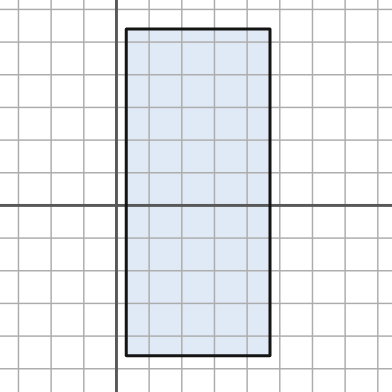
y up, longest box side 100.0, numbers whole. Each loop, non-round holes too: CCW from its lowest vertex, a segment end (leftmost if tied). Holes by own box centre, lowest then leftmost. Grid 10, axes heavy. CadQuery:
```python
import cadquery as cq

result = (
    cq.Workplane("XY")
    .moveTo(3.0, -46.0)
    .lineTo(47.0, -46.0)
    .lineTo(47.0, 54.0)
    .lineTo(3.0, 54.0)
    .close()
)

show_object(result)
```